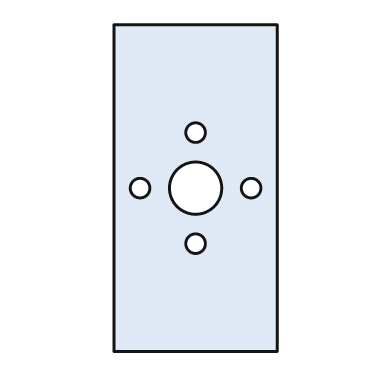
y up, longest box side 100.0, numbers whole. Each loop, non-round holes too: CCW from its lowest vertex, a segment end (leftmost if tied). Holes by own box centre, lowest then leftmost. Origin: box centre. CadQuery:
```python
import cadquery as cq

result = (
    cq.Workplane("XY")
    .moveTo(-25.0, -50.0)
    .lineTo(25.0, -50.0)
    .lineTo(25.0, 50.0)
    .lineTo(-25.0, 50.0)
    .close()
    .moveTo(0.0, -17.0)
    .circle(3.0)
    .moveTo(-17.0, 0.0)
    .circle(3.0)
    .moveTo(0.0, 0.0)
    .circle(8.0)
    .moveTo(17.0, 0.0)
    .circle(3.0)
    .moveTo(0.0, 17.0)
    .circle(3.0)
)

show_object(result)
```